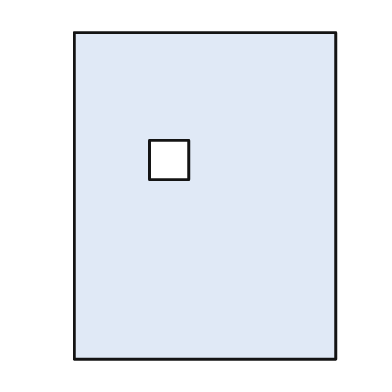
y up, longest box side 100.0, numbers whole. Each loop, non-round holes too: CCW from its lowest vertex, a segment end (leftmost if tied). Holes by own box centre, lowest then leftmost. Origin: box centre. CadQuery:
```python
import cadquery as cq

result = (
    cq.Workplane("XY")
    .moveTo(-40.0, -50.0)
    .lineTo(40.0, -50.0)
    .lineTo(40.0, 50.0)
    .lineTo(-40.0, 50.0)
    .close()
    .moveTo(-17.0, 5.0)
    .lineTo(-5.0, 5.0)
    .lineTo(-5.0, 17.0)
    .lineTo(-17.0, 17.0)
    .close()
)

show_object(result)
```